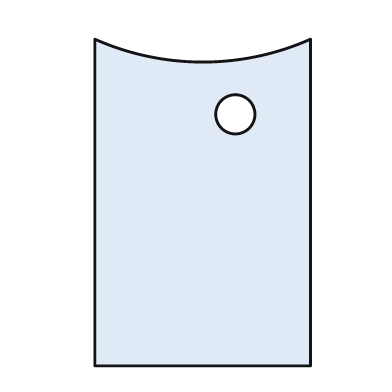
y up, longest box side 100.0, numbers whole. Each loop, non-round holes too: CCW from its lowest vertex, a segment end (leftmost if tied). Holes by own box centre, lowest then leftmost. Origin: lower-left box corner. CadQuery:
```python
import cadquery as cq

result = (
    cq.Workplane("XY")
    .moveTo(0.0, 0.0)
    .lineTo(66.0, 0.0)
    .lineTo(66.0, 100.0)
    .threePointArc((33.0, 93.0), (0.0, 100.0))
    .close()
    .moveTo(43.0, 77.0)
    .circle(6.0)
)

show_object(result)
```